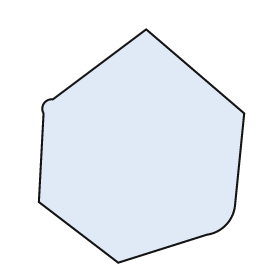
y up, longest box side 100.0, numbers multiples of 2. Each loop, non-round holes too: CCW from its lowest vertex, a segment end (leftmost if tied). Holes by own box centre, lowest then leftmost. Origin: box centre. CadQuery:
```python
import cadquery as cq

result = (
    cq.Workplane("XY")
    .moveTo(-10.0, -50.0)
    .lineTo(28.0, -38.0)
    .threePointArc((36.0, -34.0), (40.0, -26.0))
    .lineTo(44.0, 14.0)
    .lineTo(2.0, 50.0)
    .lineTo(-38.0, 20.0)
    .threePointArc((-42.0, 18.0), (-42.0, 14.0))
    .lineTo(-44.0, -24.0)
    .close()
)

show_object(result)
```